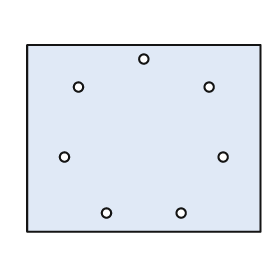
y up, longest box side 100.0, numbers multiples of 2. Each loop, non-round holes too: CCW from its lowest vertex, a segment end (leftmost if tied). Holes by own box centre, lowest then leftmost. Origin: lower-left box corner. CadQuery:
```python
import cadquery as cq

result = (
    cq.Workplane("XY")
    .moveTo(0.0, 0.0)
    .lineTo(100.0, 0.0)
    .lineTo(100.0, 80.0)
    .lineTo(0.0, 80.0)
    .close()
    .moveTo(34.0, 8.0)
    .circle(2.0)
    .moveTo(66.0, 8.0)
    .circle(2.0)
    .moveTo(16.0, 32.0)
    .circle(2.0)
    .moveTo(84.0, 32.0)
    .circle(2.0)
    .moveTo(22.0, 62.0)
    .circle(2.0)
    .moveTo(78.0, 62.0)
    .circle(2.0)
    .moveTo(50.0, 74.0)
    .circle(2.0)
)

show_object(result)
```